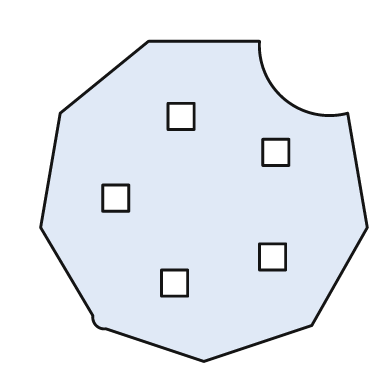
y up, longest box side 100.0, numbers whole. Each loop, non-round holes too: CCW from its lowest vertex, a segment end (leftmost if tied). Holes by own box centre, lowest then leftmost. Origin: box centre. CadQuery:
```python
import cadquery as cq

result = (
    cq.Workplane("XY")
    .moveTo(0.0, -49.0)
    .lineTo(33.0, -38.0)
    .lineTo(50.0, -8.0)
    .lineTo(44.0, 27.0)
    .threePointArc((25.0, 31.0), (17.0, 49.0))
    .lineTo(-17.0, 49.0)
    .lineTo(-44.0, 27.0)
    .lineTo(-50.0, -8.0)
    .lineTo(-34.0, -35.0)
    .threePointArc((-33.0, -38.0), (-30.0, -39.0))
    .close()
    .moveTo(-13.0, -29.0)
    .lineTo(-5.0, -29.0)
    .lineTo(-5.0, -21.0)
    .lineTo(-13.0, -21.0)
    .close()
    .moveTo(17.0, -21.0)
    .lineTo(25.0, -21.0)
    .lineTo(25.0, -13.0)
    .lineTo(17.0, -13.0)
    .close()
    .moveTo(-31.0, -3.0)
    .lineTo(-23.0, -3.0)
    .lineTo(-23.0, 5.0)
    .lineTo(-31.0, 5.0)
    .close()
    .moveTo(18.0, 11.0)
    .lineTo(26.0, 11.0)
    .lineTo(26.0, 19.0)
    .lineTo(18.0, 19.0)
    .close()
    .moveTo(-11.0, 22.0)
    .lineTo(-3.0, 22.0)
    .lineTo(-3.0, 30.0)
    .lineTo(-11.0, 30.0)
    .close()
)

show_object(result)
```